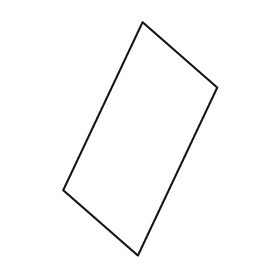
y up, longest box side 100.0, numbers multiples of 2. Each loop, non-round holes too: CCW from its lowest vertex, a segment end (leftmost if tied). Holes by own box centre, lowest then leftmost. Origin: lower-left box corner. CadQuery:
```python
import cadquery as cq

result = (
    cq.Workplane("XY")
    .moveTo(32.0, 0.0)
    .lineTo(66.0, 72.0)
    .lineTo(34.0, 100.0)
    .lineTo(0.0, 28.0)
    .close()
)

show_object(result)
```